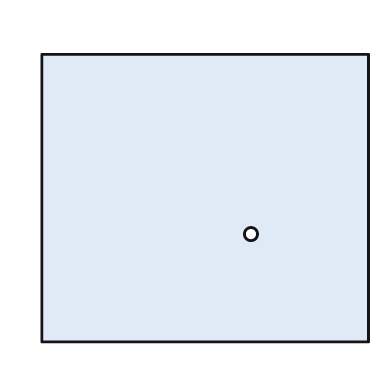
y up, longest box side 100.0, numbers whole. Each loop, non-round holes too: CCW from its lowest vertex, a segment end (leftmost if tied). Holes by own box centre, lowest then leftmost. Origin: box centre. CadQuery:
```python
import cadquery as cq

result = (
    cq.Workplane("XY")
    .moveTo(-50.0, -44.0)
    .lineTo(50.0, -44.0)
    .lineTo(50.0, 44.0)
    .lineTo(-50.0, 44.0)
    .close()
    .moveTo(14.0, -11.0)
    .circle(2.0)
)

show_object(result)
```